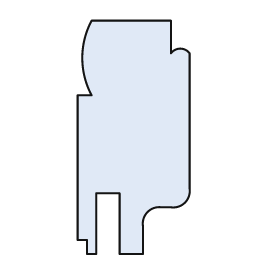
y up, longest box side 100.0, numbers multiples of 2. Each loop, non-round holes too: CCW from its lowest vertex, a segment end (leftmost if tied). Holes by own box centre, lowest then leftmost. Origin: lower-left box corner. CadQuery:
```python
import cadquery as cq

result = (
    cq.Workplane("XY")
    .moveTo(4.0, 0.0)
    .lineTo(8.0, 0.0)
    .lineTo(8.0, 26.0)
    .lineTo(18.0, 26.0)
    .lineTo(18.0, 0.0)
    .lineTo(28.0, 0.0)
    .lineTo(28.0, 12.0)
    .threePointArc((30.0, 18.0), (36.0, 20.0))
    .lineTo(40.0, 20.0)
    .threePointArc((46.0, 22.0), (48.0, 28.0))
    .lineTo(48.0, 86.0)
    .threePointArc((44.0, 88.0), (40.0, 86.0))
    .lineTo(40.0, 100.0)
    .lineTo(6.0, 100.0)
    .threePointArc((2.0, 84.0), (6.0, 68.0))
    .lineTo(0.0, 68.0)
    .lineTo(0.0, 6.0)
    .lineTo(4.0, 6.0)
    .close()
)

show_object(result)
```